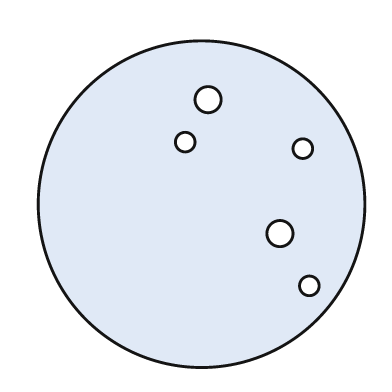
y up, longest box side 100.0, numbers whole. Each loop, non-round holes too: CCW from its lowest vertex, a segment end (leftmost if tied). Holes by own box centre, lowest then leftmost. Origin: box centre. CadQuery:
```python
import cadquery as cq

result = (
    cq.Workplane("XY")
    .moveTo(0.0, 0.0)
    .circle(50.0)
    .moveTo(33.0, -25.0)
    .circle(3.0)
    .moveTo(24.0, -9.0)
    .circle(4.0)
    .moveTo(31.0, 17.0)
    .circle(3.0)
    .moveTo(-5.0, 19.0)
    .circle(3.0)
    .moveTo(2.0, 32.0)
    .circle(4.0)
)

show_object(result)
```